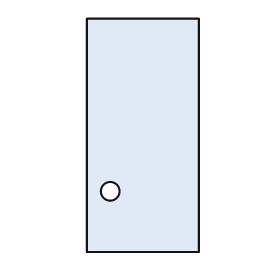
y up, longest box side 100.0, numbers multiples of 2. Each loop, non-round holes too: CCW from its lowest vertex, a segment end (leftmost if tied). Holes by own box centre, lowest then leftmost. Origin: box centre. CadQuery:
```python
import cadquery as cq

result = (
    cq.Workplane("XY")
    .moveTo(-24.0, -50.0)
    .lineTo(24.0, -50.0)
    .lineTo(24.0, 50.0)
    .lineTo(-24.0, 50.0)
    .close()
    .moveTo(-14.0, -24.0)
    .circle(4.0)
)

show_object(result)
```